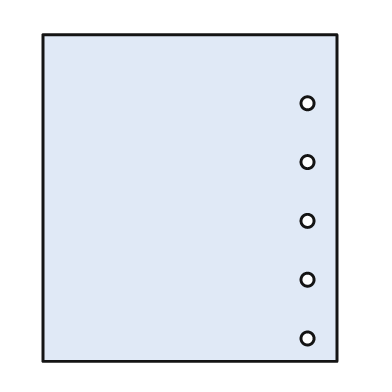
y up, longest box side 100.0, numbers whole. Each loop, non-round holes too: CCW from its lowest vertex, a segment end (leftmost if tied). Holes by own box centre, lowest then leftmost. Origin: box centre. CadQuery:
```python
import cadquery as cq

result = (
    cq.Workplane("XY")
    .moveTo(-45.0, -50.0)
    .lineTo(45.0, -50.0)
    .lineTo(45.0, 50.0)
    .lineTo(-45.0, 50.0)
    .close()
    .moveTo(36.0, -43.0)
    .circle(2.0)
    .moveTo(36.0, -25.0)
    .circle(2.0)
    .moveTo(36.0, -7.0)
    .circle(2.0)
    .moveTo(36.0, 11.0)
    .circle(2.0)
    .moveTo(36.0, 29.0)
    .circle(2.0)
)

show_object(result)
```